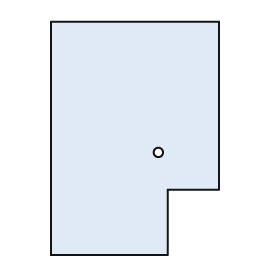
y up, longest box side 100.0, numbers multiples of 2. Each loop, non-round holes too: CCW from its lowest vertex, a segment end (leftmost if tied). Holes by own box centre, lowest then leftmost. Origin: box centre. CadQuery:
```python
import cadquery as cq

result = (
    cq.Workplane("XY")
    .moveTo(-36.0, -50.0)
    .lineTo(14.0, -50.0)
    .lineTo(14.0, -22.0)
    .lineTo(36.0, -22.0)
    .lineTo(36.0, 50.0)
    .lineTo(-36.0, 50.0)
    .close()
    .moveTo(10.0, -6.0)
    .circle(2.0)
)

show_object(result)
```